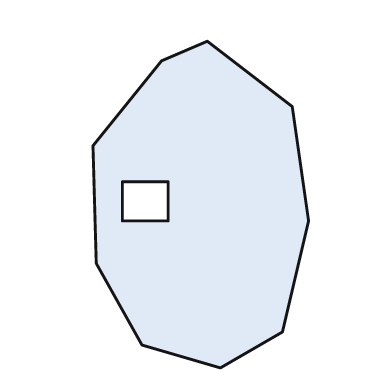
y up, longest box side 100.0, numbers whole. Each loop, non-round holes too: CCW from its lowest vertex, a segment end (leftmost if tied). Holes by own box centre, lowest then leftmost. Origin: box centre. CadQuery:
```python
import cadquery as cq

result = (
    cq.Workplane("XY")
    .moveTo(6.0, -50.0)
    .lineTo(25.0, -39.0)
    .lineTo(33.0, -5.0)
    .lineTo(28.0, 30.0)
    .lineTo(2.0, 50.0)
    .lineTo(-12.0, 44.0)
    .lineTo(-33.0, 18.0)
    .lineTo(-32.0, -18.0)
    .lineTo(-18.0, -43.0)
    .close()
    .moveTo(-24.0, -5.0)
    .lineTo(-10.0, -5.0)
    .lineTo(-10.0, 7.0)
    .lineTo(-24.0, 7.0)
    .close()
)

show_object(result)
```